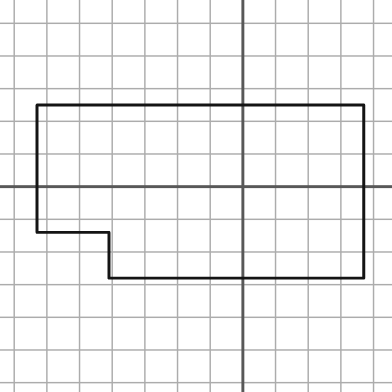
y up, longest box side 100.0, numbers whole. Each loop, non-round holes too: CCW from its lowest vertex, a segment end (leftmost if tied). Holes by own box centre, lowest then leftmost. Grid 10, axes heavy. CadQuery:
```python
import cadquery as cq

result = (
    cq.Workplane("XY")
    .moveTo(-41.0, -28.0)
    .lineTo(37.0, -28.0)
    .lineTo(37.0, 25.0)
    .lineTo(-63.0, 25.0)
    .lineTo(-63.0, -14.0)
    .lineTo(-41.0, -14.0)
    .close()
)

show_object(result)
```